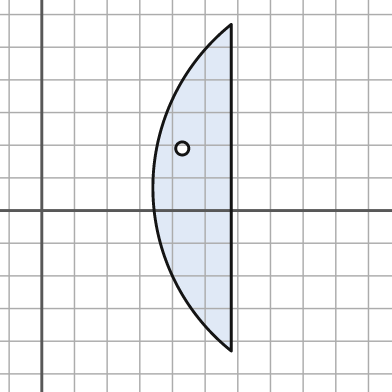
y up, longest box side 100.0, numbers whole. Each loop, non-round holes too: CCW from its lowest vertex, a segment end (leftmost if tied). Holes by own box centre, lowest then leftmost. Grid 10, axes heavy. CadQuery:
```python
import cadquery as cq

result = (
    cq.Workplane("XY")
    .moveTo(58.0, -43.0)
    .lineTo(58.0, 57.0)
    .threePointArc((34.0, 7.0), (58.0, -43.0))
    .close()
    .moveTo(43.0, 19.0)
    .circle(2.0)
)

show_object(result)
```